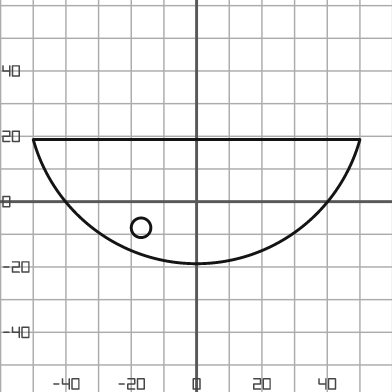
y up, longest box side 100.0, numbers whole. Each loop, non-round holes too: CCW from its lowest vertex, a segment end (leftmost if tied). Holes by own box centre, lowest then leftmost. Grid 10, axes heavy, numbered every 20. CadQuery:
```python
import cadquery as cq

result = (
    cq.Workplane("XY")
    .moveTo(-50.0, 19.0)
    .threePointArc((0.0, -19.0), (50.0, 19.0))
    .close()
    .moveTo(-17.0, -8.0)
    .circle(3.0)
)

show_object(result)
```